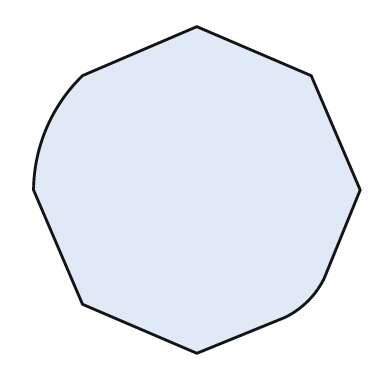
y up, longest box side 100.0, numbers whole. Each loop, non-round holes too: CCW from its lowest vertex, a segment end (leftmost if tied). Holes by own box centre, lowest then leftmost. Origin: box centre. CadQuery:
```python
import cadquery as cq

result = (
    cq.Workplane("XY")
    .moveTo(0.0, -50.0)
    .lineTo(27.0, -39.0)
    .threePointArc((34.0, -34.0), (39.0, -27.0))
    .lineTo(50.0, 0.0)
    .lineTo(35.0, 35.0)
    .lineTo(0.0, 50.0)
    .lineTo(-35.0, 35.0)
    .threePointArc((-46.0, 19.0), (-50.0, 0.0))
    .lineTo(-35.0, -35.0)
    .close()
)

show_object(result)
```